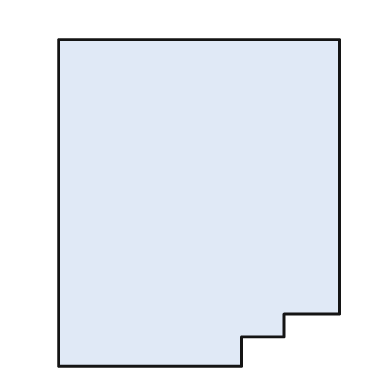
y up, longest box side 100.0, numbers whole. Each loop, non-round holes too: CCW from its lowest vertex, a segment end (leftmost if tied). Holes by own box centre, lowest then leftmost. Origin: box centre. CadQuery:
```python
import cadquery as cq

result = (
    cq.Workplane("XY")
    .moveTo(-43.0, -50.0)
    .lineTo(13.0, -50.0)
    .lineTo(13.0, -41.0)
    .lineTo(26.0, -41.0)
    .lineTo(26.0, -34.0)
    .lineTo(43.0, -34.0)
    .lineTo(43.0, 50.0)
    .lineTo(-43.0, 50.0)
    .close()
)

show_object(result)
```